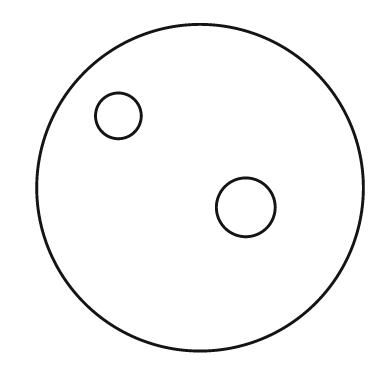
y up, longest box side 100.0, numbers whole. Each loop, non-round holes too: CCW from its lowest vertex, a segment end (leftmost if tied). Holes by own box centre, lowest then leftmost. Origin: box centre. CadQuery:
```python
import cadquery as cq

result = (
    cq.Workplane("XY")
    .moveTo(0.0, 0.0)
    .circle(50.0)
    .moveTo(14.0, -6.0)
    .circle(9.0)
    .moveTo(-25.0, 22.0)
    .circle(7.0)
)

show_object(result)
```